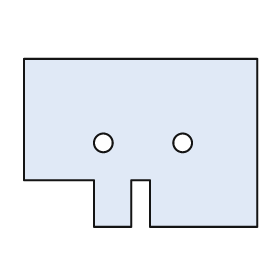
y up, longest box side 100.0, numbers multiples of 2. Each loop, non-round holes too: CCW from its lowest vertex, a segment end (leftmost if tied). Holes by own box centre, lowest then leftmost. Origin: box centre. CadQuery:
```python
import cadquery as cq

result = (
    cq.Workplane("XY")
    .moveTo(-20.0, -36.0)
    .lineTo(-4.0, -36.0)
    .lineTo(-4.0, -16.0)
    .lineTo(4.0, -16.0)
    .lineTo(4.0, -36.0)
    .lineTo(50.0, -36.0)
    .lineTo(50.0, 36.0)
    .lineTo(-50.0, 36.0)
    .lineTo(-50.0, -16.0)
    .lineTo(-20.0, -16.0)
    .close()
    .moveTo(-16.0, 0.0)
    .circle(4.0)
    .moveTo(18.0, 0.0)
    .circle(4.0)
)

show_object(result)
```